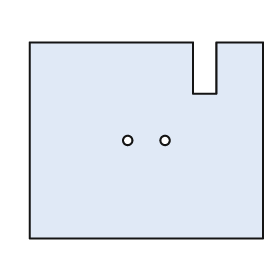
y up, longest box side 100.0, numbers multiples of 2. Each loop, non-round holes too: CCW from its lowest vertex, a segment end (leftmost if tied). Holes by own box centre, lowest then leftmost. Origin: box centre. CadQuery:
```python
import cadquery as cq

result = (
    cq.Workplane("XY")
    .moveTo(-50.0, -42.0)
    .lineTo(50.0, -42.0)
    .lineTo(50.0, 42.0)
    .lineTo(30.0, 42.0)
    .lineTo(30.0, 20.0)
    .lineTo(20.0, 20.0)
    .lineTo(20.0, 42.0)
    .lineTo(-50.0, 42.0)
    .close()
    .moveTo(-8.0, 0.0)
    .circle(2.0)
    .moveTo(8.0, 0.0)
    .circle(2.0)
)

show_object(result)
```